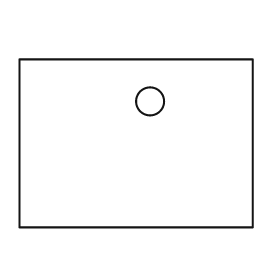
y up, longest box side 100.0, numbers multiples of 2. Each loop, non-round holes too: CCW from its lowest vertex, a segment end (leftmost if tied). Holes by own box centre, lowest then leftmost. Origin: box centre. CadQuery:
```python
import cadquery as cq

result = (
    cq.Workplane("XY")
    .moveTo(-50.0, -36.0)
    .lineTo(50.0, -36.0)
    .lineTo(50.0, 36.0)
    .lineTo(-50.0, 36.0)
    .close()
    .moveTo(6.0, 18.0)
    .circle(6.0)
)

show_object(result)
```